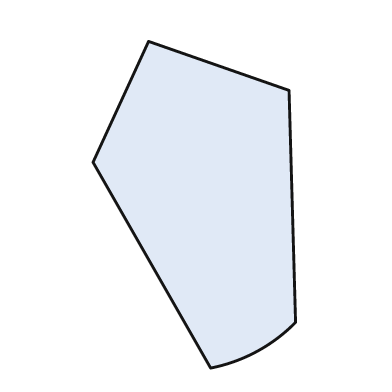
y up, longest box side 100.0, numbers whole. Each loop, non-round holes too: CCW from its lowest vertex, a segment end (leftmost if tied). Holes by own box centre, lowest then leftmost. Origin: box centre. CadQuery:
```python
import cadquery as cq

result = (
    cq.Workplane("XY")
    .moveTo(5.0, -50.0)
    .threePointArc((19.0, -45.0), (31.0, -36.0))
    .lineTo(29.0, 35.0)
    .lineTo(-14.0, 50.0)
    .lineTo(-31.0, 13.0)
    .close()
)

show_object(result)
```